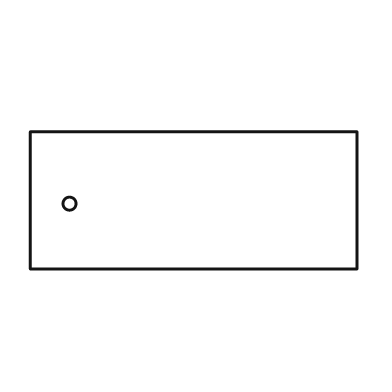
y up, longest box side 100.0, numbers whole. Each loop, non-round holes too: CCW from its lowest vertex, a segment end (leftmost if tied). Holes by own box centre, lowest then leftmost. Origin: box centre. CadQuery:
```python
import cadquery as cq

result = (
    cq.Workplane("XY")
    .moveTo(-50.0, -21.0)
    .lineTo(50.0, -21.0)
    .lineTo(50.0, 21.0)
    .lineTo(-50.0, 21.0)
    .close()
    .moveTo(-38.0, -1.0)
    .circle(2.0)
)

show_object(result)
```